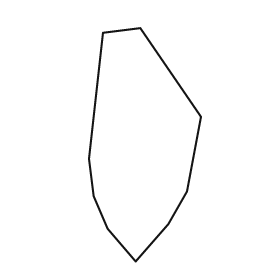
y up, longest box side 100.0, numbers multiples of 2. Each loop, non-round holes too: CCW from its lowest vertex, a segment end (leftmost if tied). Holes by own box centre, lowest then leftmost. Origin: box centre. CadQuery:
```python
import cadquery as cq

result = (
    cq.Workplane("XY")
    .moveTo(-4.0, -50.0)
    .lineTo(10.0, -34.0)
    .lineTo(18.0, -20.0)
    .lineTo(24.0, 12.0)
    .lineTo(-2.0, 50.0)
    .lineTo(-18.0, 48.0)
    .lineTo(-24.0, -6.0)
    .lineTo(-22.0, -22.0)
    .lineTo(-16.0, -36.0)
    .close()
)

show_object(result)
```